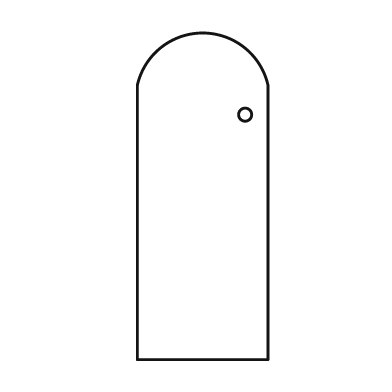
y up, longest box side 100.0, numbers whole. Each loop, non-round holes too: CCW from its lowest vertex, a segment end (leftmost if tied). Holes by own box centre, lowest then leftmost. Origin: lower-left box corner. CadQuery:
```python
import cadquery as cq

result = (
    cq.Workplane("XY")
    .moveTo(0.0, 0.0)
    .lineTo(40.0, 0.0)
    .lineTo(40.0, 84.0)
    .threePointArc((20.0, 100.0), (0.0, 84.0))
    .close()
    .moveTo(33.0, 75.0)
    .circle(2.0)
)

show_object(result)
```